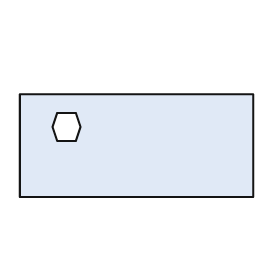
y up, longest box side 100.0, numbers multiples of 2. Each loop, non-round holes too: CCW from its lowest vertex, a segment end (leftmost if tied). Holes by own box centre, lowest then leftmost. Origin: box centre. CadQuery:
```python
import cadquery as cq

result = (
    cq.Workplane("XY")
    .moveTo(-50.0, -22.0)
    .lineTo(50.0, -22.0)
    .lineTo(50.0, 22.0)
    .lineTo(-50.0, 22.0)
    .close()
    .moveTo(-34.0, 2.0)
    .lineTo(-26.0, 2.0)
    .lineTo(-24.0, 8.0)
    .lineTo(-26.0, 14.0)
    .lineTo(-34.0, 14.0)
    .lineTo(-36.0, 8.0)
    .close()
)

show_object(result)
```